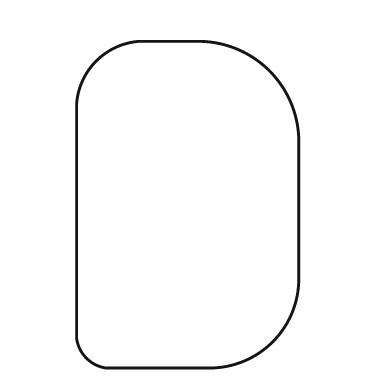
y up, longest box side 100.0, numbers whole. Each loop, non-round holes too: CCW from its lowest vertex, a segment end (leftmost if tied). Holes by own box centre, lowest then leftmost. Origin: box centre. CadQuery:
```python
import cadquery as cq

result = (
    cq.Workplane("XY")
    .moveTo(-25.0, -50.0)
    .lineTo(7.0, -50.0)
    .threePointArc((26.0, -42.0), (34.0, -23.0))
    .lineTo(34.0, 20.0)
    .threePointArc((25.0, 41.0), (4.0, 50.0))
    .lineTo(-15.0, 50.0)
    .threePointArc((-28.0, 44.0), (-34.0, 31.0))
    .lineTo(-34.0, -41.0)
    .threePointArc((-31.0, -47.0), (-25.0, -50.0))
    .close()
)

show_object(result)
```